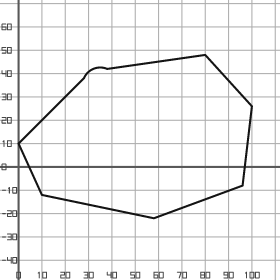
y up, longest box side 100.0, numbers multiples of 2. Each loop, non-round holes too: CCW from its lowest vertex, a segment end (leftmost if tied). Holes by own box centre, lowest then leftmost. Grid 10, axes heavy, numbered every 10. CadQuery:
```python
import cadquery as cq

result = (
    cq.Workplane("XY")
    .moveTo(58.0, -22.0)
    .lineTo(96.0, -8.0)
    .lineTo(100.0, 26.0)
    .lineTo(80.0, 48.0)
    .lineTo(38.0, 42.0)
    .threePointArc((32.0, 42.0), (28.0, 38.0))
    .lineTo(0.0, 10.0)
    .lineTo(10.0, -12.0)
    .close()
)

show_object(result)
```